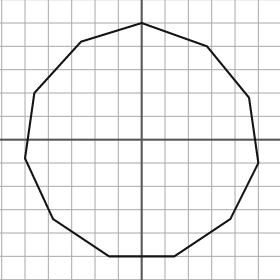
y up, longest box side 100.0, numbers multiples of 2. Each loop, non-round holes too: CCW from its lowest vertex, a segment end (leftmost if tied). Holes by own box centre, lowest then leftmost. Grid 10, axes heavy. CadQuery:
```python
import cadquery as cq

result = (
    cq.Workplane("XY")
    .moveTo(-14.0, -50.0)
    .lineTo(14.0, -50.0)
    .lineTo(38.0, -34.0)
    .lineTo(50.0, -10.0)
    .lineTo(46.0, 18.0)
    .lineTo(28.0, 40.0)
    .lineTo(0.0, 50.0)
    .lineTo(-26.0, 42.0)
    .lineTo(-46.0, 20.0)
    .lineTo(-50.0, -8.0)
    .lineTo(-38.0, -34.0)
    .close()
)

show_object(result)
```